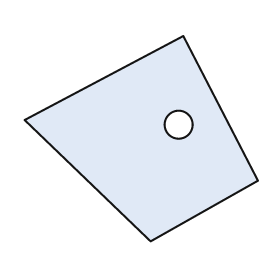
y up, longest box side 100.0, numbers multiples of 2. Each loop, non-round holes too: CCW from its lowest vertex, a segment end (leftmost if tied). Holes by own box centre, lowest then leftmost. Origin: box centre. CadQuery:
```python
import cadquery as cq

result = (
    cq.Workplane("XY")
    .moveTo(4.0, -44.0)
    .lineTo(50.0, -18.0)
    .lineTo(18.0, 44.0)
    .lineTo(-50.0, 8.0)
    .close()
    .moveTo(16.0, 6.0)
    .circle(6.0)
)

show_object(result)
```